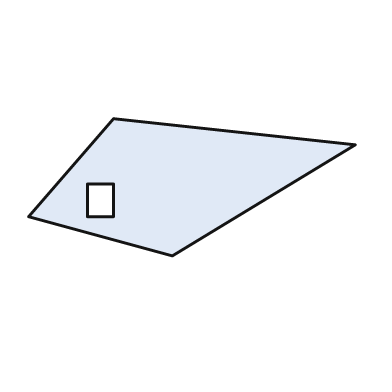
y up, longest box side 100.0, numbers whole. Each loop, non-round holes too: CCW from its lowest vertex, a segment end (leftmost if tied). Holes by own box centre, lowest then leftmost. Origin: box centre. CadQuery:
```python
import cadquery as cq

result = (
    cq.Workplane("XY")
    .moveTo(-6.0, -21.0)
    .lineTo(50.0, 13.0)
    .lineTo(-24.0, 21.0)
    .lineTo(-50.0, -9.0)
    .close()
    .moveTo(-32.0, -9.0)
    .lineTo(-24.0, -9.0)
    .lineTo(-24.0, 1.0)
    .lineTo(-32.0, 1.0)
    .close()
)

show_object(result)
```